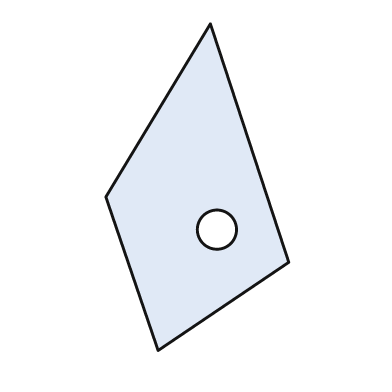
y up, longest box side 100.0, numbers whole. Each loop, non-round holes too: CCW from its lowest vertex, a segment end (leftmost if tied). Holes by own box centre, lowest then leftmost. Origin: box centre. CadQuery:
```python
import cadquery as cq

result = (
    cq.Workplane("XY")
    .moveTo(-12.0, -50.0)
    .lineTo(28.0, -23.0)
    .lineTo(4.0, 50.0)
    .lineTo(-28.0, -3.0)
    .close()
    .moveTo(6.0, -13.0)
    .circle(6.0)
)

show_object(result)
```